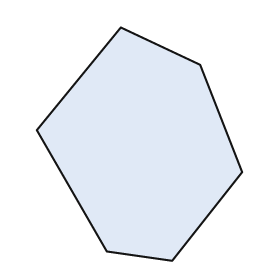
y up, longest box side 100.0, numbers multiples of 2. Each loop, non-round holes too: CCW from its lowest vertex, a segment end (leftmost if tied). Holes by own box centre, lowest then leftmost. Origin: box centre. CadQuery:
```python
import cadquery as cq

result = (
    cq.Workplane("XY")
    .moveTo(14.0, -50.0)
    .lineTo(44.0, -12.0)
    .lineTo(26.0, 34.0)
    .lineTo(-8.0, 50.0)
    .lineTo(-44.0, 6.0)
    .lineTo(-14.0, -46.0)
    .close()
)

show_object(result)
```